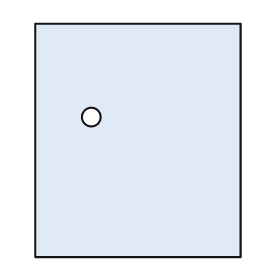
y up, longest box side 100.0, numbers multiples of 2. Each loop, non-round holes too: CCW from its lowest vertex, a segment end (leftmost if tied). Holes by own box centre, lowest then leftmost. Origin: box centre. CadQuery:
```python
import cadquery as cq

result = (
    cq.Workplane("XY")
    .moveTo(-44.0, -50.0)
    .lineTo(44.0, -50.0)
    .lineTo(44.0, 50.0)
    .lineTo(-44.0, 50.0)
    .close()
    .moveTo(-20.0, 10.0)
    .circle(4.0)
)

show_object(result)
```